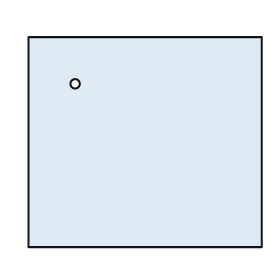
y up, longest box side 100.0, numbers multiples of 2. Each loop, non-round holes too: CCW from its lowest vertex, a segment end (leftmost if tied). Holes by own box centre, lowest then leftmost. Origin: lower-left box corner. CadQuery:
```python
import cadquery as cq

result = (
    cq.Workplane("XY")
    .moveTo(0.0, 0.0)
    .lineTo(100.0, 0.0)
    .lineTo(100.0, 90.0)
    .lineTo(0.0, 90.0)
    .close()
    .moveTo(20.0, 70.0)
    .circle(2.0)
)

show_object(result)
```